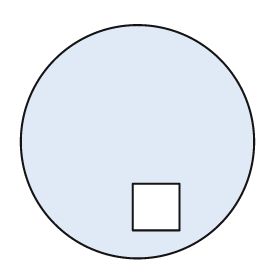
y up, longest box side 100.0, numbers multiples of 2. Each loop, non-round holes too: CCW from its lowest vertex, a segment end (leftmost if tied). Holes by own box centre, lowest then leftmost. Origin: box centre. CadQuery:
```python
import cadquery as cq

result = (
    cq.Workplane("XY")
    .moveTo(0.0, 0.0)
    .circle(50.0)
    .moveTo(-2.0, -38.0)
    .lineTo(18.0, -38.0)
    .lineTo(18.0, -18.0)
    .lineTo(-2.0, -18.0)
    .close()
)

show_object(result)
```